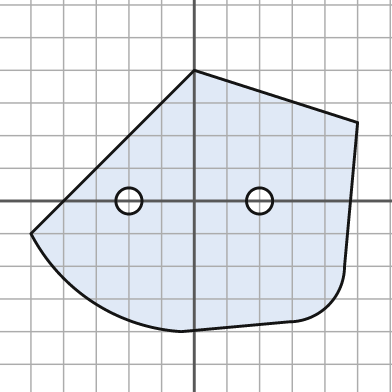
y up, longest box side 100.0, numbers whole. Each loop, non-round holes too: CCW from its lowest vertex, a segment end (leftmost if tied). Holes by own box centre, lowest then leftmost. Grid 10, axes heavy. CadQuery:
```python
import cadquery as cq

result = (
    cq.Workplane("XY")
    .moveTo(-4.0, -40.0)
    .lineTo(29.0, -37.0)
    .threePointArc((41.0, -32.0), (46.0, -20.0))
    .lineTo(50.0, 24.0)
    .lineTo(0.0, 40.0)
    .lineTo(-50.0, -10.0)
    .threePointArc((-31.0, -31.0), (-4.0, -40.0))
    .close()
    .moveTo(-20.0, 0.0)
    .circle(4.0)
    .moveTo(20.0, 0.0)
    .circle(4.0)
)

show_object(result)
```